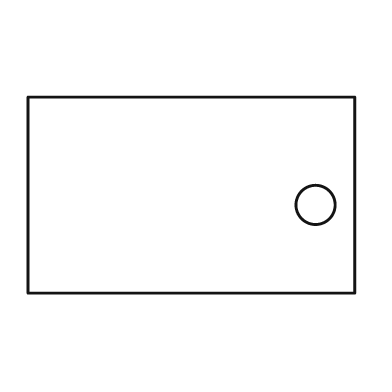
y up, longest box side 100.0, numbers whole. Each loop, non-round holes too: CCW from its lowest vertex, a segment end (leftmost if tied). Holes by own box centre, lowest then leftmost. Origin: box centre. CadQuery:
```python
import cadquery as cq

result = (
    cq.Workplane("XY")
    .moveTo(-50.0, -30.0)
    .lineTo(50.0, -30.0)
    .lineTo(50.0, 30.0)
    .lineTo(-50.0, 30.0)
    .close()
    .moveTo(38.0, -3.0)
    .circle(6.0)
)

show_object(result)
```